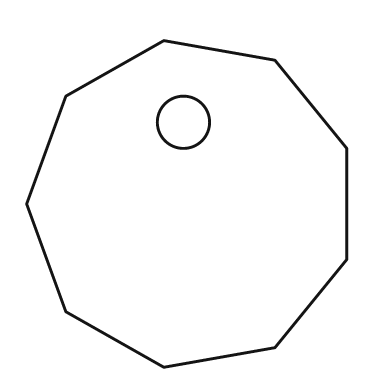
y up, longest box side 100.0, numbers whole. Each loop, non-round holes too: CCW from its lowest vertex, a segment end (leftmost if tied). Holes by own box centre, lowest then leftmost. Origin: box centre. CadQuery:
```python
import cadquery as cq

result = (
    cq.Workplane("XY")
    .moveTo(-7.0, -50.0)
    .lineTo(27.0, -44.0)
    .lineTo(49.0, -17.0)
    .lineTo(49.0, 17.0)
    .lineTo(27.0, 44.0)
    .lineTo(-7.0, 50.0)
    .lineTo(-37.0, 33.0)
    .lineTo(-49.0, 0.0)
    .lineTo(-37.0, -33.0)
    .close()
    .moveTo(-1.0, 25.0)
    .circle(8.0)
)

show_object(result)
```